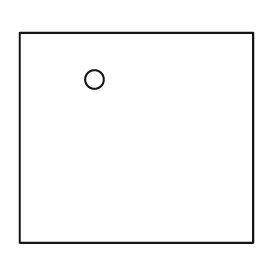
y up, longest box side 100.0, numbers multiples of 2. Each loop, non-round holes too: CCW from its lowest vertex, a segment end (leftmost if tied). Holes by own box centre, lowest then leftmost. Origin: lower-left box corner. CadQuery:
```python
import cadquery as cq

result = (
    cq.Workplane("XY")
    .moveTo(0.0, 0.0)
    .lineTo(100.0, 0.0)
    .lineTo(100.0, 90.0)
    .lineTo(0.0, 90.0)
    .close()
    .moveTo(32.0, 70.0)
    .circle(4.0)
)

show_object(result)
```